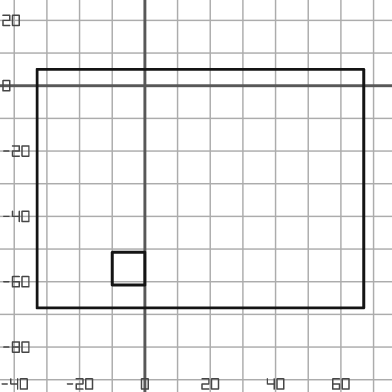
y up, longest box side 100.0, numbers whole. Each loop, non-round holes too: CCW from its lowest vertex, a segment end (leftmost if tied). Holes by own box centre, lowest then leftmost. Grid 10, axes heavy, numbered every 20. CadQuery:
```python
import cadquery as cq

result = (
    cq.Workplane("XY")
    .moveTo(-33.0, -68.0)
    .lineTo(67.0, -68.0)
    .lineTo(67.0, 5.0)
    .lineTo(-33.0, 5.0)
    .close()
    .moveTo(-10.0, -61.0)
    .lineTo(0.0, -61.0)
    .lineTo(0.0, -51.0)
    .lineTo(-10.0, -51.0)
    .close()
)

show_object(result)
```